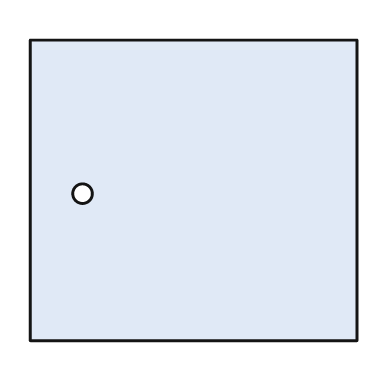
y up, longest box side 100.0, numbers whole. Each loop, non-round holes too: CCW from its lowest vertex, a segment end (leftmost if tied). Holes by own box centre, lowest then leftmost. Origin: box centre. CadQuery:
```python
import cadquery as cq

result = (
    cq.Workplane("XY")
    .moveTo(-50.0, -46.0)
    .lineTo(50.0, -46.0)
    .lineTo(50.0, 46.0)
    .lineTo(-50.0, 46.0)
    .close()
    .moveTo(-34.0, -1.0)
    .circle(3.0)
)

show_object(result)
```